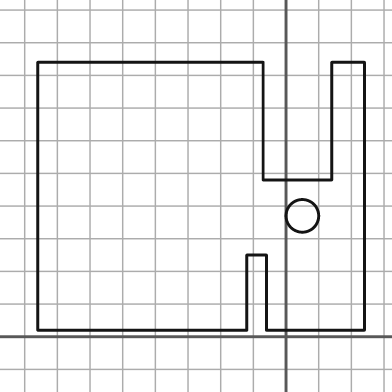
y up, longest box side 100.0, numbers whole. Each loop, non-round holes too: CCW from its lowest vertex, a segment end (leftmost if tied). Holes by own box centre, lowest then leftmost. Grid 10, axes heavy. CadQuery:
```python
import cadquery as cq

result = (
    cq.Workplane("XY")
    .moveTo(-76.0, 2.0)
    .lineTo(-12.0, 2.0)
    .lineTo(-12.0, 25.0)
    .lineTo(-6.0, 25.0)
    .lineTo(-6.0, 2.0)
    .lineTo(24.0, 2.0)
    .lineTo(24.0, 84.0)
    .lineTo(14.0, 84.0)
    .lineTo(14.0, 48.0)
    .lineTo(-7.0, 48.0)
    .lineTo(-7.0, 84.0)
    .lineTo(-76.0, 84.0)
    .close()
    .moveTo(5.0, 37.0)
    .circle(5.0)
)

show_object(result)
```